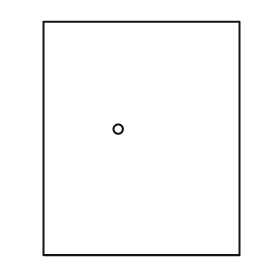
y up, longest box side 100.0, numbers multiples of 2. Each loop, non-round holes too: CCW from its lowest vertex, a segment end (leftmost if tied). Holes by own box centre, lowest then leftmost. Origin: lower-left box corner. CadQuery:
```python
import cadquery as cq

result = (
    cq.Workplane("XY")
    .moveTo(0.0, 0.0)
    .lineTo(84.0, 0.0)
    .lineTo(84.0, 100.0)
    .lineTo(0.0, 100.0)
    .close()
    .moveTo(32.0, 54.0)
    .circle(2.0)
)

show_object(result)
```